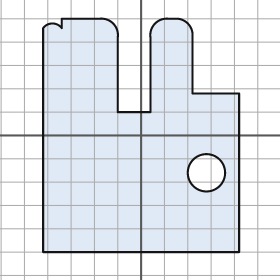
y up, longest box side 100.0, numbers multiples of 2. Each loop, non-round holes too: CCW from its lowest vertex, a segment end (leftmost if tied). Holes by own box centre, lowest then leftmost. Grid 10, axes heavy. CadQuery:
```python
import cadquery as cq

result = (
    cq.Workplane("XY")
    .moveTo(-42.0, -50.0)
    .lineTo(42.0, -50.0)
    .lineTo(42.0, 18.0)
    .lineTo(22.0, 18.0)
    .lineTo(22.0, 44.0)
    .threePointArc((20.0, 48.0), (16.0, 50.0))
    .lineTo(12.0, 50.0)
    .threePointArc((6.0, 48.0), (4.0, 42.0))
    .lineTo(4.0, 10.0)
    .lineTo(-10.0, 10.0)
    .lineTo(-10.0, 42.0)
    .threePointArc((-12.0, 48.0), (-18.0, 50.0))
    .lineTo(-34.0, 50.0)
    .lineTo(-34.0, 46.0)
    .threePointArc((-38.0, 48.0), (-42.0, 46.0))
    .close()
    .moveTo(28.0, -16.0)
    .circle(8.0)
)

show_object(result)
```